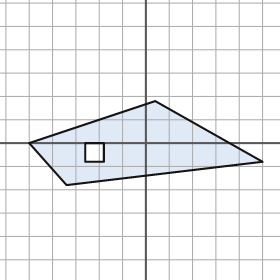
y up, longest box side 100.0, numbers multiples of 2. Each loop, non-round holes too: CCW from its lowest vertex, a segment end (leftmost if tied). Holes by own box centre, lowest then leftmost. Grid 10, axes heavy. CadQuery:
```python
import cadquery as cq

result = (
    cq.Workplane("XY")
    .moveTo(-34.0, -18.0)
    .lineTo(50.0, -8.0)
    .lineTo(4.0, 18.0)
    .lineTo(-50.0, 0.0)
    .close()
    .moveTo(-26.0, -8.0)
    .lineTo(-18.0, -8.0)
    .lineTo(-18.0, 0.0)
    .lineTo(-26.0, 0.0)
    .close()
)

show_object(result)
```